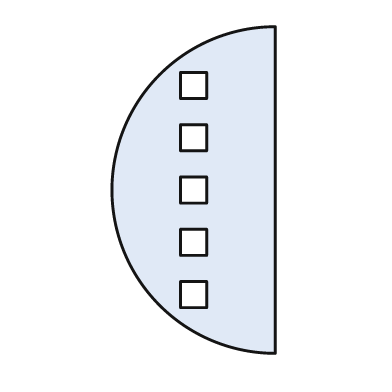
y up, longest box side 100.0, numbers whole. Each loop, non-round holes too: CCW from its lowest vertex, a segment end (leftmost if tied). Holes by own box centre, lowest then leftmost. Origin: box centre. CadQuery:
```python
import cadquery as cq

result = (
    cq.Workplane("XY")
    .moveTo(25.0, -50.0)
    .lineTo(25.0, 50.0)
    .threePointArc((-25.0, 0.0), (25.0, -50.0))
    .close()
    .moveTo(-4.0, -36.0)
    .lineTo(4.0, -36.0)
    .lineTo(4.0, -28.0)
    .lineTo(-4.0, -28.0)
    .close()
    .moveTo(-4.0, -20.0)
    .lineTo(4.0, -20.0)
    .lineTo(4.0, -12.0)
    .lineTo(-4.0, -12.0)
    .close()
    .moveTo(-4.0, -4.0)
    .lineTo(4.0, -4.0)
    .lineTo(4.0, 4.0)
    .lineTo(-4.0, 4.0)
    .close()
    .moveTo(-4.0, 12.0)
    .lineTo(4.0, 12.0)
    .lineTo(4.0, 20.0)
    .lineTo(-4.0, 20.0)
    .close()
    .moveTo(-4.0, 28.0)
    .lineTo(4.0, 28.0)
    .lineTo(4.0, 36.0)
    .lineTo(-4.0, 36.0)
    .close()
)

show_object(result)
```